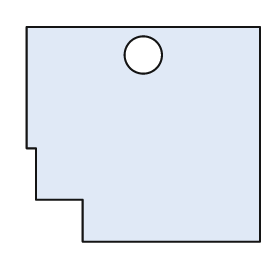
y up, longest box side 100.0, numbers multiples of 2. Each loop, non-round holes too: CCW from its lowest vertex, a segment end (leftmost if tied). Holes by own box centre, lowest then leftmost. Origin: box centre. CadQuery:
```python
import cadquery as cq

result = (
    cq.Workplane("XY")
    .moveTo(-26.0, -46.0)
    .lineTo(50.0, -46.0)
    .lineTo(50.0, 46.0)
    .lineTo(-50.0, 46.0)
    .lineTo(-50.0, -6.0)
    .lineTo(-46.0, -6.0)
    .lineTo(-46.0, -28.0)
    .lineTo(-26.0, -28.0)
    .close()
    .moveTo(0.0, 34.0)
    .circle(8.0)
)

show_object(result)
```